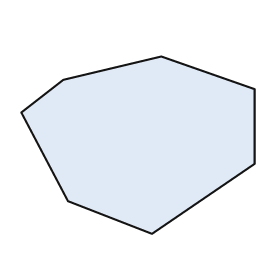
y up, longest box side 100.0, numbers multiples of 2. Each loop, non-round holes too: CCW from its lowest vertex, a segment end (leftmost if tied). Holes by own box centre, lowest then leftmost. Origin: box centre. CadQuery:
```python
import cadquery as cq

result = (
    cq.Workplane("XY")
    .moveTo(6.0, -38.0)
    .lineTo(50.0, -8.0)
    .lineTo(50.0, 24.0)
    .lineTo(10.0, 38.0)
    .lineTo(-32.0, 28.0)
    .lineTo(-50.0, 14.0)
    .lineTo(-30.0, -24.0)
    .close()
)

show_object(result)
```